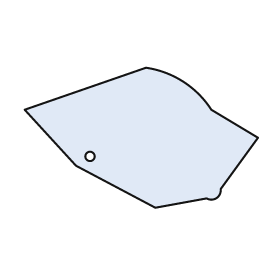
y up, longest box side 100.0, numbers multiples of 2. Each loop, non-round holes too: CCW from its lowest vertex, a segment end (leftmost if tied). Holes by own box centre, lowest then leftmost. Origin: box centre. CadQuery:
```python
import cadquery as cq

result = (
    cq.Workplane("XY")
    .moveTo(6.0, -30.0)
    .lineTo(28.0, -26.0)
    .threePointArc((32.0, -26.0), (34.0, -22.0))
    .lineTo(50.0, 0.0)
    .lineTo(30.0, 12.0)
    .threePointArc((18.0, 24.0), (2.0, 30.0))
    .lineTo(-50.0, 12.0)
    .lineTo(-28.0, -12.0)
    .close()
    .moveTo(-22.0, -8.0)
    .circle(2.0)
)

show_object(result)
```